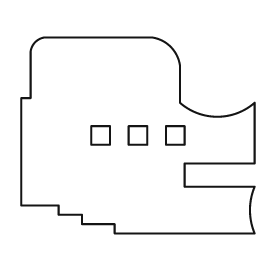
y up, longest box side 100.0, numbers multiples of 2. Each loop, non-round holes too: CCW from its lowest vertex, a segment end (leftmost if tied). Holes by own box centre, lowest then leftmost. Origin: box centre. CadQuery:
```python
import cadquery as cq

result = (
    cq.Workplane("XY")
    .moveTo(-10.0, -42.0)
    .lineTo(50.0, -42.0)
    .threePointArc((48.0, -32.0), (50.0, -22.0))
    .lineTo(20.0, -22.0)
    .lineTo(20.0, -12.0)
    .lineTo(50.0, -12.0)
    .lineTo(50.0, 14.0)
    .threePointArc((34.0, 8.0), (18.0, 14.0))
    .lineTo(18.0, 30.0)
    .threePointArc((14.0, 38.0), (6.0, 42.0))
    .lineTo(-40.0, 42.0)
    .threePointArc((-44.0, 40.0), (-46.0, 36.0))
    .lineTo(-46.0, 16.0)
    .lineTo(-50.0, 16.0)
    .lineTo(-50.0, -30.0)
    .lineTo(-34.0, -30.0)
    .lineTo(-34.0, -34.0)
    .lineTo(-24.0, -34.0)
    .lineTo(-24.0, -38.0)
    .lineTo(-10.0, -38.0)
    .close()
    .moveTo(-20.0, -4.0)
    .lineTo(-12.0, -4.0)
    .lineTo(-12.0, 4.0)
    .lineTo(-20.0, 4.0)
    .close()
    .moveTo(-4.0, -4.0)
    .lineTo(4.0, -4.0)
    .lineTo(4.0, 4.0)
    .lineTo(-4.0, 4.0)
    .close()
    .moveTo(12.0, -4.0)
    .lineTo(20.0, -4.0)
    .lineTo(20.0, 4.0)
    .lineTo(12.0, 4.0)
    .close()
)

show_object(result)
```